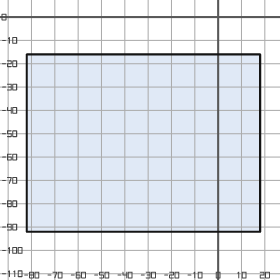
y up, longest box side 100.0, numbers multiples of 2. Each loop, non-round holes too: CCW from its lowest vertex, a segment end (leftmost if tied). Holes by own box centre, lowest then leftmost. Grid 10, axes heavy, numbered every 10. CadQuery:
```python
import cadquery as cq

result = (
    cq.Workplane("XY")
    .moveTo(-82.0, -92.0)
    .lineTo(18.0, -92.0)
    .lineTo(18.0, -16.0)
    .lineTo(-82.0, -16.0)
    .close()
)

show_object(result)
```